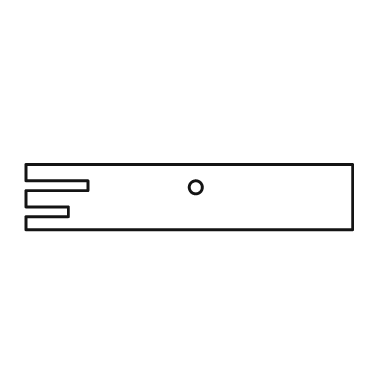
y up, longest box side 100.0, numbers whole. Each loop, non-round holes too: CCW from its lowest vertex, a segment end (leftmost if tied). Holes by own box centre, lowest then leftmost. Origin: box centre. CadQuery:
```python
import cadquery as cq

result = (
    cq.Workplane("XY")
    .moveTo(-50.0, -10.0)
    .lineTo(50.0, -10.0)
    .lineTo(50.0, 10.0)
    .lineTo(-50.0, 10.0)
    .lineTo(-50.0, 5.0)
    .lineTo(-31.0, 5.0)
    .lineTo(-31.0, 2.0)
    .lineTo(-50.0, 2.0)
    .lineTo(-50.0, -3.0)
    .lineTo(-37.0, -3.0)
    .lineTo(-37.0, -6.0)
    .lineTo(-50.0, -6.0)
    .close()
    .moveTo(2.0, 3.0)
    .circle(2.0)
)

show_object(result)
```